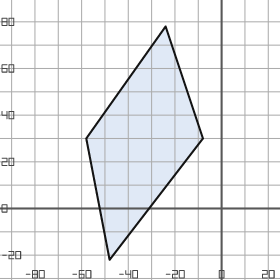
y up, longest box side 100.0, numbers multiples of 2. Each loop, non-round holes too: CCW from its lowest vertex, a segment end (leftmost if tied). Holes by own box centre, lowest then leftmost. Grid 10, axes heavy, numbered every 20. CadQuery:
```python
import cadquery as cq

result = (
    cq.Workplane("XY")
    .moveTo(-48.0, -22.0)
    .lineTo(-8.0, 30.0)
    .lineTo(-24.0, 78.0)
    .lineTo(-58.0, 30.0)
    .close()
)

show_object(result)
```